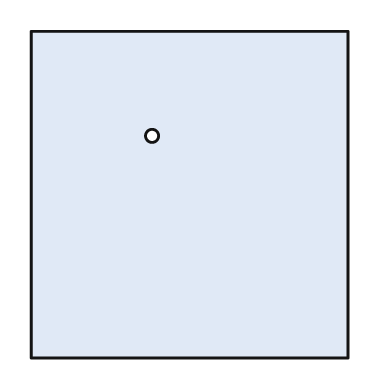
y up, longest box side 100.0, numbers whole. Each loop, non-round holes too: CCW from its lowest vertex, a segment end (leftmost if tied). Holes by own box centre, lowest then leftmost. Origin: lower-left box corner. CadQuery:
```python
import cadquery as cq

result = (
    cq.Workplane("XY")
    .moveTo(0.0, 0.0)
    .lineTo(97.0, 0.0)
    .lineTo(97.0, 100.0)
    .lineTo(0.0, 100.0)
    .close()
    .moveTo(37.0, 68.0)
    .circle(2.0)
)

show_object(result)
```